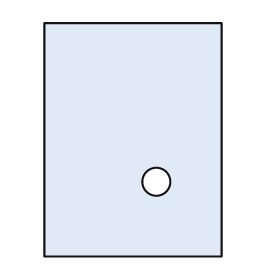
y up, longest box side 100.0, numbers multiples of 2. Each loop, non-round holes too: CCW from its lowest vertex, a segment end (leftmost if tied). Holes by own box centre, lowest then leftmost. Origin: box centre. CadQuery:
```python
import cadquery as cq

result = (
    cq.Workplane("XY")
    .moveTo(-38.0, -50.0)
    .lineTo(38.0, -50.0)
    .lineTo(38.0, 50.0)
    .lineTo(-38.0, 50.0)
    .close()
    .moveTo(10.0, -18.0)
    .circle(6.0)
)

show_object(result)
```